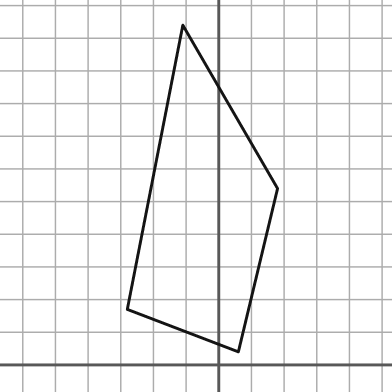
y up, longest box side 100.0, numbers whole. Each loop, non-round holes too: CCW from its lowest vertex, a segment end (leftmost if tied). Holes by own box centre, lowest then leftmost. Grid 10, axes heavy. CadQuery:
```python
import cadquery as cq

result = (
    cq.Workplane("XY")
    .moveTo(6.0, 4.0)
    .lineTo(18.0, 54.0)
    .lineTo(-11.0, 104.0)
    .lineTo(-28.0, 17.0)
    .close()
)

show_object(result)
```